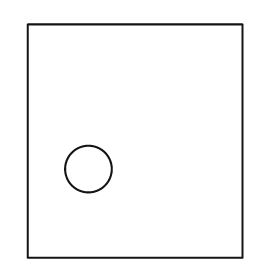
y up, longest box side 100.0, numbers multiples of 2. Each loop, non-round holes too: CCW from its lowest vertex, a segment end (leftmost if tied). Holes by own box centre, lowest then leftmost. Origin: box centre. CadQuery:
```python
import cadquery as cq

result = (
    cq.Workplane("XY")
    .moveTo(-46.0, -50.0)
    .lineTo(46.0, -50.0)
    .lineTo(46.0, 50.0)
    .lineTo(-46.0, 50.0)
    .close()
    .moveTo(-20.0, -12.0)
    .circle(10.0)
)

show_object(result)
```